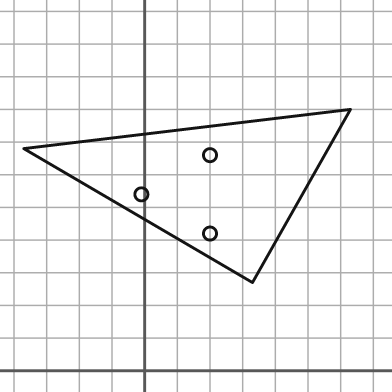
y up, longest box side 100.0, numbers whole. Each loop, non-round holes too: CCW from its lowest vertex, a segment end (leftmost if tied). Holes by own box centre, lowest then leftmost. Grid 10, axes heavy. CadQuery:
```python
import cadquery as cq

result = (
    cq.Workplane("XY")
    .moveTo(33.0, 27.0)
    .lineTo(63.0, 80.0)
    .lineTo(-37.0, 68.0)
    .close()
    .moveTo(20.0, 42.0)
    .circle(2.0)
    .moveTo(-1.0, 54.0)
    .circle(2.0)
    .moveTo(20.0, 66.0)
    .circle(2.0)
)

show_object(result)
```